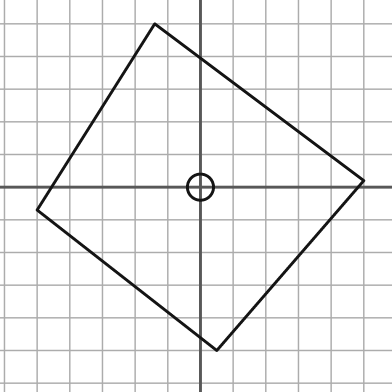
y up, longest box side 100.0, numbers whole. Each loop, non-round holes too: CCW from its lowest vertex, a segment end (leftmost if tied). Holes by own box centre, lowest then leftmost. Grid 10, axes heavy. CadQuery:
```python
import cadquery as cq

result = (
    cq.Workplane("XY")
    .moveTo(5.0, -50.0)
    .lineTo(50.0, 2.0)
    .lineTo(-14.0, 50.0)
    .lineTo(-50.0, -7.0)
    .close()
    .moveTo(0.0, 0.0)
    .circle(4.0)
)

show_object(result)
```